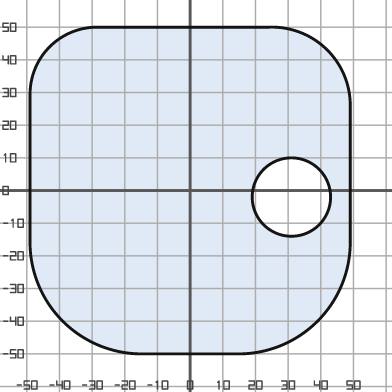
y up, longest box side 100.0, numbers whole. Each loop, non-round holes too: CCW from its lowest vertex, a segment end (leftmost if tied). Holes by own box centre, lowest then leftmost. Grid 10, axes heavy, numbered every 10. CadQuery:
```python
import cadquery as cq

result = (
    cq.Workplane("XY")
    .moveTo(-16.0, -50.0)
    .lineTo(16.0, -50.0)
    .threePointArc((39.0, -40.0), (49.0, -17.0))
    .lineTo(49.0, 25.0)
    .threePointArc((42.0, 43.0), (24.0, 50.0))
    .lineTo(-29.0, 50.0)
    .threePointArc((-43.0, 44.0), (-49.0, 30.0))
    .lineTo(-49.0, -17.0)
    .threePointArc((-39.0, -40.0), (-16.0, -50.0))
    .close()
    .moveTo(31.0, -2.0)
    .circle(12.0)
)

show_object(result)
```